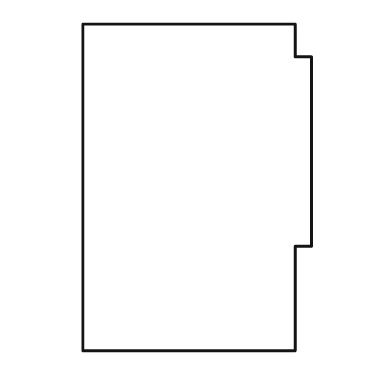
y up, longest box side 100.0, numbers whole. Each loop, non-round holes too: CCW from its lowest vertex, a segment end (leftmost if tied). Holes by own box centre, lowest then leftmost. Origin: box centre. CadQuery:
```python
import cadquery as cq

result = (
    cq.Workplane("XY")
    .moveTo(-35.0, -50.0)
    .lineTo(30.0, -50.0)
    .lineTo(30.0, -18.0)
    .lineTo(35.0, -18.0)
    .lineTo(35.0, 40.0)
    .lineTo(30.0, 40.0)
    .lineTo(30.0, 50.0)
    .lineTo(-35.0, 50.0)
    .close()
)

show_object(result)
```